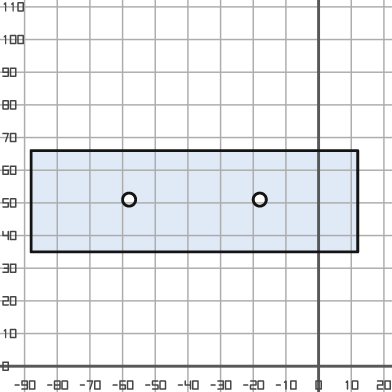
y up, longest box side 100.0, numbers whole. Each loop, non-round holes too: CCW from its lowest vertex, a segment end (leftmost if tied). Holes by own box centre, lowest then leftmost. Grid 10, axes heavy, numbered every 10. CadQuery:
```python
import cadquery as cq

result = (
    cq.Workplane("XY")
    .moveTo(-88.0, 35.0)
    .lineTo(12.0, 35.0)
    .lineTo(12.0, 66.0)
    .lineTo(-88.0, 66.0)
    .close()
    .moveTo(-58.0, 51.0)
    .circle(2.0)
    .moveTo(-18.0, 51.0)
    .circle(2.0)
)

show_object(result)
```